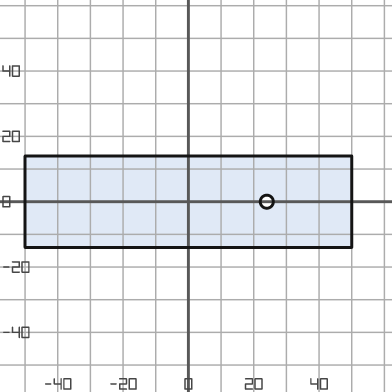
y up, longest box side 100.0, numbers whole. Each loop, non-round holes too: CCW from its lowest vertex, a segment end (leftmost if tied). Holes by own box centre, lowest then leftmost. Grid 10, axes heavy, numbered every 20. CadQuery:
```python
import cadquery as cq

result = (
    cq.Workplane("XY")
    .moveTo(-50.0, -14.0)
    .lineTo(50.0, -14.0)
    .lineTo(50.0, 14.0)
    .lineTo(-50.0, 14.0)
    .close()
    .moveTo(24.0, 0.0)
    .circle(2.0)
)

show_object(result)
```